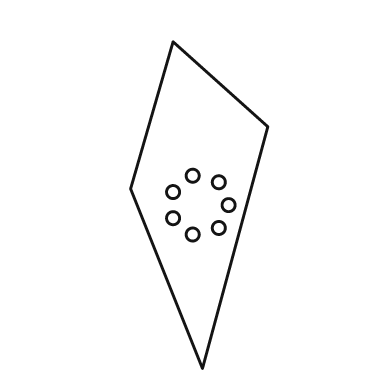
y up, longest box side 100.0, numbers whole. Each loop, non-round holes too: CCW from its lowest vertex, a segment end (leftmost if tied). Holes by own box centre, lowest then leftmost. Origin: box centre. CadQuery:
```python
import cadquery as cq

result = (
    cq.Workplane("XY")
    .moveTo(1.0, -50.0)
    .lineTo(21.0, 24.0)
    .lineTo(-8.0, 50.0)
    .lineTo(-21.0, 5.0)
    .close()
    .moveTo(-2.0, -9.0)
    .circle(2.0)
    .moveTo(6.0, -7.0)
    .circle(2.0)
    .moveTo(-8.0, -4.0)
    .circle(2.0)
    .moveTo(9.0, 0.0)
    .circle(2.0)
    .moveTo(-8.0, 4.0)
    .circle(2.0)
    .moveTo(6.0, 7.0)
    .circle(2.0)
    .moveTo(-2.0, 9.0)
    .circle(2.0)
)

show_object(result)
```